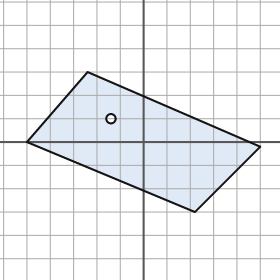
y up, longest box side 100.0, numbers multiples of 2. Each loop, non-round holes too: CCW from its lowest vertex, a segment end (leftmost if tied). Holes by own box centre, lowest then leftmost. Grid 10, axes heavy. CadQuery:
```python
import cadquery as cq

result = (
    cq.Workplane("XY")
    .moveTo(22.0, -30.0)
    .lineTo(50.0, -2.0)
    .lineTo(-24.0, 30.0)
    .lineTo(-50.0, 0.0)
    .close()
    .moveTo(-14.0, 10.0)
    .circle(2.0)
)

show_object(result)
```